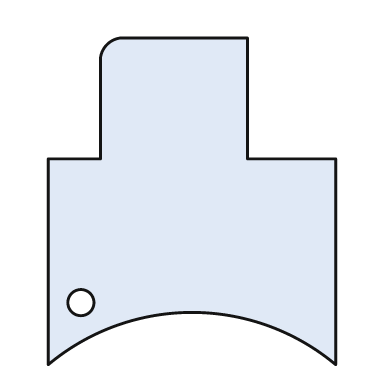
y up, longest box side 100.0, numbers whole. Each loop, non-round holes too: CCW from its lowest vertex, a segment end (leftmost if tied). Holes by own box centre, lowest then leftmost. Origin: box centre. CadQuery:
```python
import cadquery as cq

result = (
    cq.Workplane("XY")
    .moveTo(-44.0, -50.0)
    .threePointArc((0.0, -34.0), (44.0, -50.0))
    .lineTo(44.0, 13.0)
    .lineTo(17.0, 13.0)
    .lineTo(17.0, 50.0)
    .lineTo(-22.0, 50.0)
    .threePointArc((-26.0, 48.0), (-28.0, 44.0))
    .lineTo(-28.0, 13.0)
    .lineTo(-44.0, 13.0)
    .close()
    .moveTo(-34.0, -31.0)
    .circle(4.0)
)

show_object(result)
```